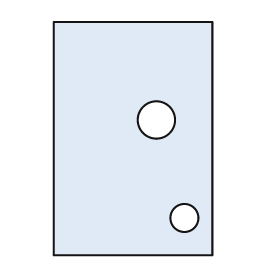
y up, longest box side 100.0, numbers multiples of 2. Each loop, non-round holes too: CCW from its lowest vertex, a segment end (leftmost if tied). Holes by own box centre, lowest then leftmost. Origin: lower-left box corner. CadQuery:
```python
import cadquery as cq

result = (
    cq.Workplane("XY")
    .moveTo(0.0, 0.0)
    .lineTo(68.0, 0.0)
    .lineTo(68.0, 100.0)
    .lineTo(0.0, 100.0)
    .close()
    .moveTo(56.0, 16.0)
    .circle(6.0)
    .moveTo(44.0, 58.0)
    .circle(8.0)
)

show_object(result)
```